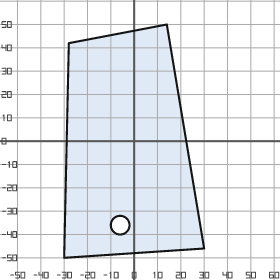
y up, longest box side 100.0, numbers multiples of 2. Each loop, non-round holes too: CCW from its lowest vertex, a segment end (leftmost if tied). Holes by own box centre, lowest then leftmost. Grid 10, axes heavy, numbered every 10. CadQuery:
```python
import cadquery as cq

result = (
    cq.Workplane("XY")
    .moveTo(-30.0, -50.0)
    .lineTo(30.0, -46.0)
    .lineTo(14.0, 50.0)
    .lineTo(-28.0, 42.0)
    .close()
    .moveTo(-6.0, -36.0)
    .circle(4.0)
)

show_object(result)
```